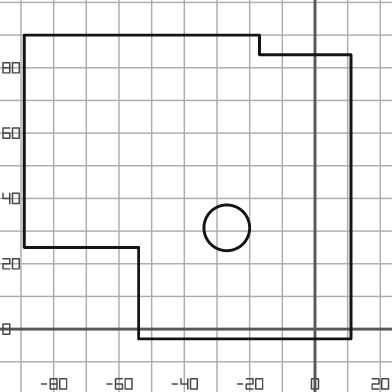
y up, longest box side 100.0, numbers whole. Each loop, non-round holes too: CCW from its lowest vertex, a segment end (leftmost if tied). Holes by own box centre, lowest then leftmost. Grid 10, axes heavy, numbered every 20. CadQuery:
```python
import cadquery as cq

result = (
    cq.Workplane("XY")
    .moveTo(-54.0, -3.0)
    .lineTo(11.0, -3.0)
    .lineTo(11.0, 84.0)
    .lineTo(-17.0, 84.0)
    .lineTo(-17.0, 90.0)
    .lineTo(-89.0, 90.0)
    .lineTo(-89.0, 25.0)
    .lineTo(-54.0, 25.0)
    .close()
    .moveTo(-27.0, 31.0)
    .circle(7.0)
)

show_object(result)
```